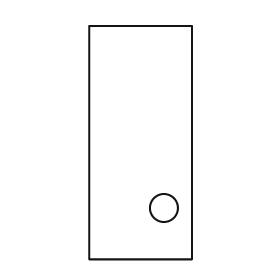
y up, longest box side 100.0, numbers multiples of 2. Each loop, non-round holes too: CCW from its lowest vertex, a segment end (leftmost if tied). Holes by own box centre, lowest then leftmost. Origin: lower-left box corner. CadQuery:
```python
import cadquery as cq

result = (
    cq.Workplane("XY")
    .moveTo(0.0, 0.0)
    .lineTo(44.0, 0.0)
    .lineTo(44.0, 100.0)
    .lineTo(0.0, 100.0)
    .close()
    .moveTo(32.0, 22.0)
    .circle(6.0)
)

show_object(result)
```